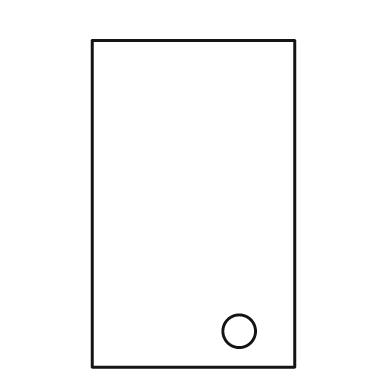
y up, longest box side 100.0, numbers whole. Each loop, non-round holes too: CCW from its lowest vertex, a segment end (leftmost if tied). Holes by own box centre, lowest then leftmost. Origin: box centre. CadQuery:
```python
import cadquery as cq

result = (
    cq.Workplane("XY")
    .moveTo(-31.0, -50.0)
    .lineTo(31.0, -50.0)
    .lineTo(31.0, 50.0)
    .lineTo(-31.0, 50.0)
    .close()
    .moveTo(14.0, -39.0)
    .circle(5.0)
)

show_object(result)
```